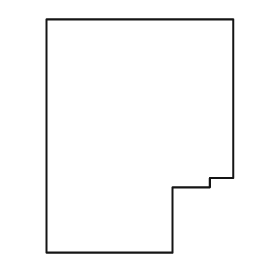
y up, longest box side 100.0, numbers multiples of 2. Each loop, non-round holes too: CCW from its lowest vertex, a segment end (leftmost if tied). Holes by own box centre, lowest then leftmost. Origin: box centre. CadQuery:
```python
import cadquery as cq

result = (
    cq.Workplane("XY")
    .moveTo(-40.0, -50.0)
    .lineTo(14.0, -50.0)
    .lineTo(14.0, -22.0)
    .lineTo(30.0, -22.0)
    .lineTo(30.0, -18.0)
    .lineTo(40.0, -18.0)
    .lineTo(40.0, 50.0)
    .lineTo(-40.0, 50.0)
    .close()
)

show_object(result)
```